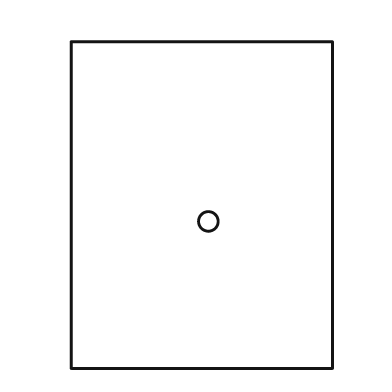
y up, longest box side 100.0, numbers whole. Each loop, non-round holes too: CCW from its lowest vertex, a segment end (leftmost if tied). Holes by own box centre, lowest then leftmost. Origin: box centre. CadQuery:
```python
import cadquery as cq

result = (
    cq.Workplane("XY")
    .moveTo(-40.0, -50.0)
    .lineTo(40.0, -50.0)
    .lineTo(40.0, 50.0)
    .lineTo(-40.0, 50.0)
    .close()
    .moveTo(2.0, -5.0)
    .circle(3.0)
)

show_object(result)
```